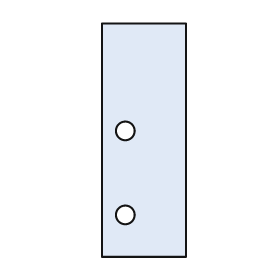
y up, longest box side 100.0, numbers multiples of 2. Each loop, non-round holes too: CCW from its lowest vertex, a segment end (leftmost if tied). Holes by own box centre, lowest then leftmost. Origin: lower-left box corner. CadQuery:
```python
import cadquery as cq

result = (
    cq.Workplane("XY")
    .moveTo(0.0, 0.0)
    .lineTo(36.0, 0.0)
    .lineTo(36.0, 100.0)
    .lineTo(0.0, 100.0)
    .close()
    .moveTo(10.0, 18.0)
    .circle(4.0)
    .moveTo(10.0, 54.0)
    .circle(4.0)
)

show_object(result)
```